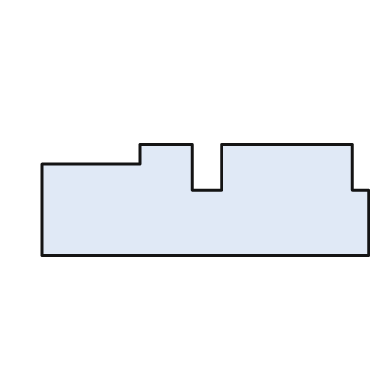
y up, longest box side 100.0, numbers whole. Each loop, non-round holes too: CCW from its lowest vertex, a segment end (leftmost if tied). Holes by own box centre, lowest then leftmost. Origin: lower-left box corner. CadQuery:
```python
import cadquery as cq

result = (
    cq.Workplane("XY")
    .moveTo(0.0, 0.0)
    .lineTo(100.0, 0.0)
    .lineTo(100.0, 20.0)
    .lineTo(95.0, 20.0)
    .lineTo(95.0, 34.0)
    .lineTo(55.0, 34.0)
    .lineTo(55.0, 20.0)
    .lineTo(46.0, 20.0)
    .lineTo(46.0, 34.0)
    .lineTo(30.0, 34.0)
    .lineTo(30.0, 28.0)
    .lineTo(0.0, 28.0)
    .close()
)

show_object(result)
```